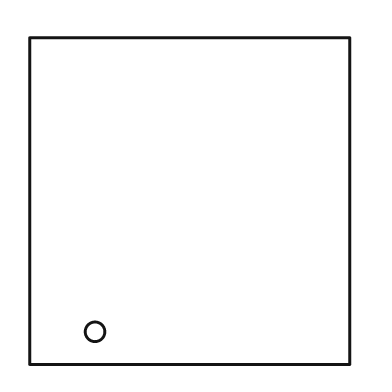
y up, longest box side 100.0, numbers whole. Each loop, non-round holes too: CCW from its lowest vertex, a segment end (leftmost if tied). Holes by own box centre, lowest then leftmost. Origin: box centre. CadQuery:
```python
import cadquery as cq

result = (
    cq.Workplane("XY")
    .moveTo(-49.0, -50.0)
    .lineTo(49.0, -50.0)
    .lineTo(49.0, 50.0)
    .lineTo(-49.0, 50.0)
    .close()
    .moveTo(-29.0, -40.0)
    .circle(3.0)
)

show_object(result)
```